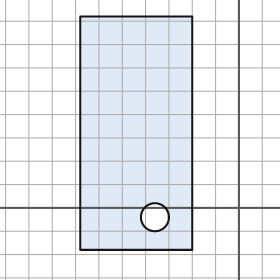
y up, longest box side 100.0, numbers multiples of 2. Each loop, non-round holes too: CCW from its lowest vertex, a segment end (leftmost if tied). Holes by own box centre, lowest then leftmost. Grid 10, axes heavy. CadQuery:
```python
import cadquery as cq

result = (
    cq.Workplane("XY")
    .moveTo(-68.0, -18.0)
    .lineTo(-20.0, -18.0)
    .lineTo(-20.0, 82.0)
    .lineTo(-68.0, 82.0)
    .close()
    .moveTo(-36.0, -4.0)
    .circle(6.0)
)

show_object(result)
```